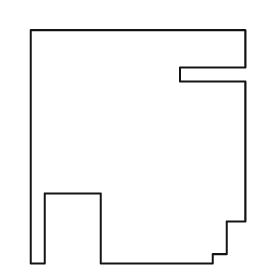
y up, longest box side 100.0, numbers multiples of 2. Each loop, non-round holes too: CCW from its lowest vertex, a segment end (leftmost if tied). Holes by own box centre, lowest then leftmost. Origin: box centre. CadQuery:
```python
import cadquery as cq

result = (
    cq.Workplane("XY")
    .moveTo(-46.0, -50.0)
    .lineTo(-40.0, -50.0)
    .lineTo(-40.0, -20.0)
    .lineTo(-16.0, -20.0)
    .lineTo(-16.0, -50.0)
    .lineTo(32.0, -50.0)
    .lineTo(32.0, -46.0)
    .lineTo(38.0, -46.0)
    .lineTo(38.0, -32.0)
    .lineTo(46.0, -32.0)
    .lineTo(46.0, 28.0)
    .lineTo(18.0, 28.0)
    .lineTo(18.0, 34.0)
    .lineTo(46.0, 34.0)
    .lineTo(46.0, 50.0)
    .lineTo(-46.0, 50.0)
    .close()
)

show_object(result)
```